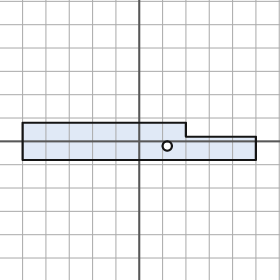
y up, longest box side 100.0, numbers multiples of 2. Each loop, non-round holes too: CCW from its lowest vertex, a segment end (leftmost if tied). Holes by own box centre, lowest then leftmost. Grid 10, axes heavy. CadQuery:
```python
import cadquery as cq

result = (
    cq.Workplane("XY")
    .moveTo(-50.0, -8.0)
    .lineTo(50.0, -8.0)
    .lineTo(50.0, 2.0)
    .lineTo(20.0, 2.0)
    .lineTo(20.0, 8.0)
    .lineTo(-50.0, 8.0)
    .close()
    .moveTo(12.0, -2.0)
    .circle(2.0)
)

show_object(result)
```